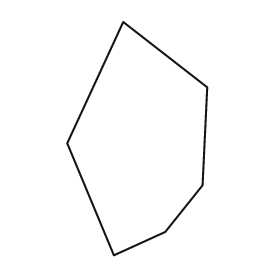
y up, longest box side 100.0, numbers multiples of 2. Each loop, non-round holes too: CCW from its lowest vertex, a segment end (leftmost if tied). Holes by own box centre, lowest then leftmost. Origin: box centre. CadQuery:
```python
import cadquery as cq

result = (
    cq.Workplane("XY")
    .moveTo(-10.0, -50.0)
    .lineTo(12.0, -40.0)
    .lineTo(28.0, -20.0)
    .lineTo(30.0, 22.0)
    .lineTo(-6.0, 50.0)
    .lineTo(-30.0, -2.0)
    .close()
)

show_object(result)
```